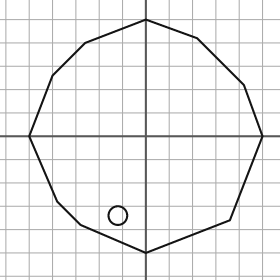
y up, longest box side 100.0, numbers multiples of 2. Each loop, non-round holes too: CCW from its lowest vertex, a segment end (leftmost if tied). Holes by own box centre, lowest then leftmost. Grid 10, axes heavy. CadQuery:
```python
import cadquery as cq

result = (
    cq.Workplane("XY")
    .moveTo(0.0, -50.0)
    .lineTo(36.0, -36.0)
    .lineTo(50.0, 0.0)
    .lineTo(42.0, 22.0)
    .lineTo(22.0, 42.0)
    .lineTo(0.0, 50.0)
    .lineTo(-26.0, 40.0)
    .lineTo(-40.0, 26.0)
    .lineTo(-50.0, 0.0)
    .lineTo(-38.0, -28.0)
    .lineTo(-28.0, -38.0)
    .close()
    .moveTo(-12.0, -34.0)
    .circle(4.0)
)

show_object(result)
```